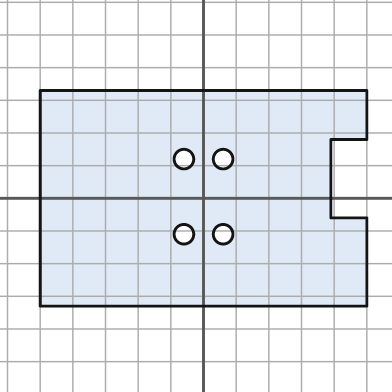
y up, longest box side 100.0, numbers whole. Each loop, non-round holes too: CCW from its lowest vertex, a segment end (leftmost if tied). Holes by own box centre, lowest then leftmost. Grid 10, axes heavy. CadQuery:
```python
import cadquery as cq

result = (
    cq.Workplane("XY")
    .moveTo(-50.0, -33.0)
    .lineTo(50.0, -33.0)
    .lineTo(50.0, -6.0)
    .lineTo(39.0, -6.0)
    .lineTo(39.0, 18.0)
    .lineTo(50.0, 18.0)
    .lineTo(50.0, 33.0)
    .lineTo(-50.0, 33.0)
    .close()
    .moveTo(-6.0, -11.0)
    .circle(3.0)
    .moveTo(6.0, -11.0)
    .circle(3.0)
    .moveTo(-6.0, 12.0)
    .circle(3.0)
    .moveTo(6.0, 12.0)
    .circle(3.0)
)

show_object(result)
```